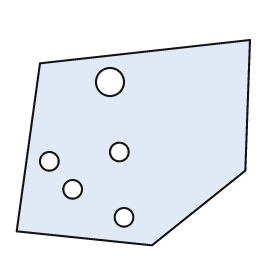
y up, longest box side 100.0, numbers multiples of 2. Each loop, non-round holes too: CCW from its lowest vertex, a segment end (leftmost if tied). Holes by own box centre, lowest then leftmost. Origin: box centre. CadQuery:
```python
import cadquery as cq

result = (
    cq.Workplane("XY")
    .moveTo(8.0, -44.0)
    .lineTo(48.0, -12.0)
    .lineTo(50.0, 44.0)
    .lineTo(-40.0, 34.0)
    .lineTo(-50.0, -38.0)
    .close()
    .moveTo(-4.0, -32.0)
    .circle(4.0)
    .moveTo(-26.0, -20.0)
    .circle(4.0)
    .moveTo(-36.0, -8.0)
    .circle(4.0)
    .moveTo(-6.0, -4.0)
    .circle(4.0)
    .moveTo(-10.0, 26.0)
    .circle(6.0)
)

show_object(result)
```